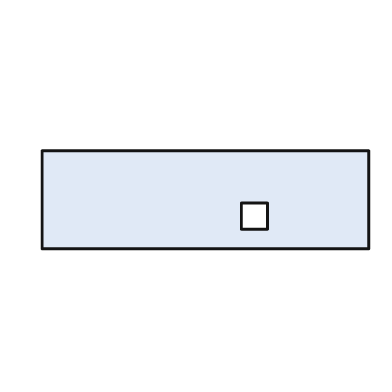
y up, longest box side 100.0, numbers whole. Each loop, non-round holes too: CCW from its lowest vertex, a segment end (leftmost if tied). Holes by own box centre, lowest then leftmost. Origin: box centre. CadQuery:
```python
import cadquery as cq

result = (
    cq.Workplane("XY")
    .moveTo(-50.0, -15.0)
    .lineTo(50.0, -15.0)
    .lineTo(50.0, 15.0)
    .lineTo(-50.0, 15.0)
    .close()
    .moveTo(11.0, -9.0)
    .lineTo(19.0, -9.0)
    .lineTo(19.0, -1.0)
    .lineTo(11.0, -1.0)
    .close()
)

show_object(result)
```